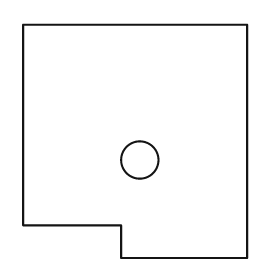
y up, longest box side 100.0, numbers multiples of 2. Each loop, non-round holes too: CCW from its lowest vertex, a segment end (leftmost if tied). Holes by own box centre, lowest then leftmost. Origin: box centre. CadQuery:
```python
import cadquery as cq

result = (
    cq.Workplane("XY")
    .moveTo(-6.0, -50.0)
    .lineTo(48.0, -50.0)
    .lineTo(48.0, 50.0)
    .lineTo(-48.0, 50.0)
    .lineTo(-48.0, -36.0)
    .lineTo(-6.0, -36.0)
    .close()
    .moveTo(2.0, -8.0)
    .circle(8.0)
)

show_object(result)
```